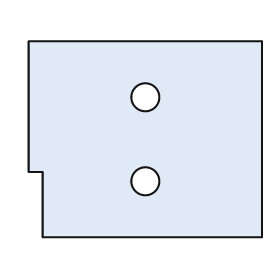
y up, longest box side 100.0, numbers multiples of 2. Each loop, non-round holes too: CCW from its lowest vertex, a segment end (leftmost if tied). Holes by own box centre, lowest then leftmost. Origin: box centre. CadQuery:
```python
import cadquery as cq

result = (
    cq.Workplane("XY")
    .moveTo(-44.0, -42.0)
    .lineTo(50.0, -42.0)
    .lineTo(50.0, 42.0)
    .lineTo(-50.0, 42.0)
    .lineTo(-50.0, -14.0)
    .lineTo(-44.0, -14.0)
    .close()
    .moveTo(0.0, -18.0)
    .circle(6.0)
    .moveTo(0.0, 18.0)
    .circle(6.0)
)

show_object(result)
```